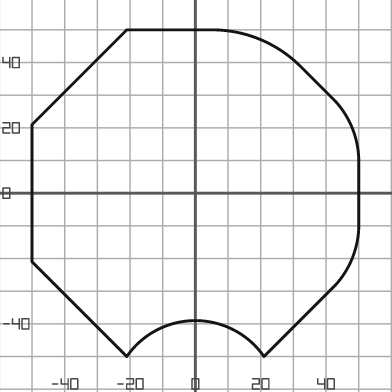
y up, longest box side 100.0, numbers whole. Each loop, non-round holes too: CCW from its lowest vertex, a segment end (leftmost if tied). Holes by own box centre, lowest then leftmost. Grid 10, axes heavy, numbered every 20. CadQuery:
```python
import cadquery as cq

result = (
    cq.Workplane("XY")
    .moveTo(-21.0, -50.0)
    .threePointArc((0.0, -39.0), (21.0, -50.0))
    .lineTo(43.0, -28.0)
    .threePointArc((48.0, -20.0), (50.0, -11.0))
    .lineTo(50.0, 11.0)
    .threePointArc((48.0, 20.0), (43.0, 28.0))
    .lineTo(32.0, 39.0)
    .threePointArc((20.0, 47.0), (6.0, 50.0))
    .lineTo(-21.0, 50.0)
    .lineTo(-50.0, 21.0)
    .lineTo(-50.0, -21.0)
    .close()
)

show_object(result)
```